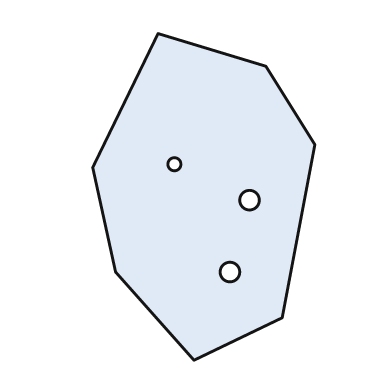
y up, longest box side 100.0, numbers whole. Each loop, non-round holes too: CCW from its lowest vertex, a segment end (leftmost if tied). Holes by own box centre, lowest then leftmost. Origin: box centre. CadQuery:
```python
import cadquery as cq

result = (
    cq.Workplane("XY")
    .moveTo(-3.0, -50.0)
    .lineTo(24.0, -37.0)
    .lineTo(34.0, 16.0)
    .lineTo(19.0, 40.0)
    .lineTo(-14.0, 50.0)
    .lineTo(-34.0, 9.0)
    .lineTo(-27.0, -23.0)
    .close()
    .moveTo(8.0, -23.0)
    .circle(3.0)
    .moveTo(14.0, -1.0)
    .circle(3.0)
    .moveTo(-9.0, 10.0)
    .circle(2.0)
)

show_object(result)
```